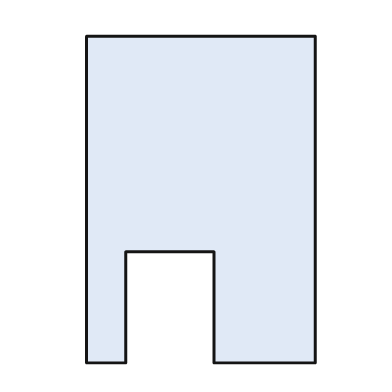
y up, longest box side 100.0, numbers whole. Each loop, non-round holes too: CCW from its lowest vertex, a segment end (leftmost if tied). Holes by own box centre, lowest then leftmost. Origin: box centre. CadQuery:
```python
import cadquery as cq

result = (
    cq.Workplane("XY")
    .moveTo(-35.0, -50.0)
    .lineTo(-23.0, -50.0)
    .lineTo(-23.0, -16.0)
    .lineTo(4.0, -16.0)
    .lineTo(4.0, -50.0)
    .lineTo(35.0, -50.0)
    .lineTo(35.0, 50.0)
    .lineTo(-35.0, 50.0)
    .close()
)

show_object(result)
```